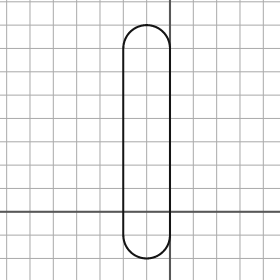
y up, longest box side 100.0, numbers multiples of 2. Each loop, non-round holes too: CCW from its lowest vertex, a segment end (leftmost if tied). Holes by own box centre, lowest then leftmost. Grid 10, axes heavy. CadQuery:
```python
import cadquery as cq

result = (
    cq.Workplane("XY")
    .moveTo(-20.0, -10.0)
    .threePointArc((-10.0, -20.0), (0.0, -10.0))
    .lineTo(0.0, 70.0)
    .threePointArc((-10.0, 80.0), (-20.0, 70.0))
    .close()
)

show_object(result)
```